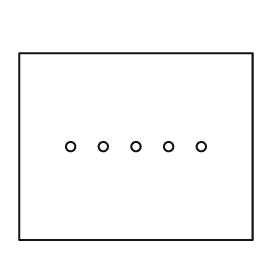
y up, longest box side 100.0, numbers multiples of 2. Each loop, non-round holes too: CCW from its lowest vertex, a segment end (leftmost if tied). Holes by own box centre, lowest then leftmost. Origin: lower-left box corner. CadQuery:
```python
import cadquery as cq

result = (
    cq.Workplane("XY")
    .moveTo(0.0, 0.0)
    .lineTo(100.0, 0.0)
    .lineTo(100.0, 80.0)
    .lineTo(0.0, 80.0)
    .close()
    .moveTo(22.0, 40.0)
    .circle(2.0)
    .moveTo(36.0, 40.0)
    .circle(2.0)
    .moveTo(50.0, 40.0)
    .circle(2.0)
    .moveTo(64.0, 40.0)
    .circle(2.0)
    .moveTo(78.0, 40.0)
    .circle(2.0)
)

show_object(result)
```